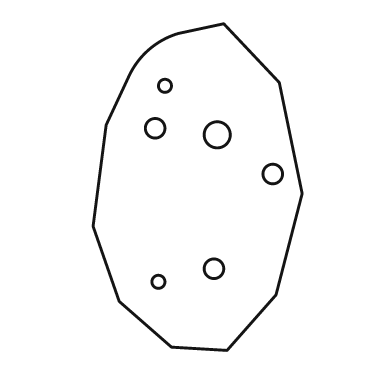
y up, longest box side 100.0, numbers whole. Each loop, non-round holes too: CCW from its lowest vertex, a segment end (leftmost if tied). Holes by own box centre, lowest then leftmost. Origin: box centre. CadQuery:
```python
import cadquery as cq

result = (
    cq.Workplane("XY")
    .moveTo(9.0, -50.0)
    .lineTo(24.0, -33.0)
    .lineTo(32.0, -2.0)
    .lineTo(25.0, 32.0)
    .lineTo(8.0, 50.0)
    .lineTo(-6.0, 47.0)
    .threePointArc((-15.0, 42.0), (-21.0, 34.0))
    .lineTo(-28.0, 19.0)
    .lineTo(-32.0, -12.0)
    .lineTo(-24.0, -35.0)
    .lineTo(-8.0, -49.0)
    .close()
    .moveTo(-12.0, -29.0)
    .circle(2.0)
    .moveTo(5.0, -25.0)
    .circle(3.0)
    .moveTo(23.0, 4.0)
    .circle(3.0)
    .moveTo(6.0, 16.0)
    .circle(4.0)
    .moveTo(-13.0, 18.0)
    .circle(3.0)
    .moveTo(-10.0, 31.0)
    .circle(2.0)
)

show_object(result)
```